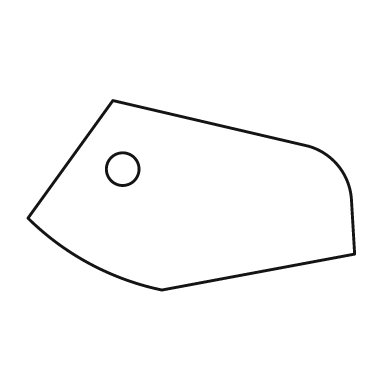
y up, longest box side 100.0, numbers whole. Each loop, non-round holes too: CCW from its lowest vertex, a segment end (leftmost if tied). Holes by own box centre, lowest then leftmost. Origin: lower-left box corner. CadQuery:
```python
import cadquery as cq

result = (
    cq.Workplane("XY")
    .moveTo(41.0, 0.0)
    .lineTo(100.0, 11.0)
    .lineTo(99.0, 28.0)
    .threePointArc((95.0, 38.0), (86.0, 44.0))
    .lineTo(26.0, 58.0)
    .lineTo(0.0, 22.0)
    .threePointArc((19.0, 8.0), (41.0, 0.0))
    .close()
    .moveTo(29.0, 37.0)
    .circle(5.0)
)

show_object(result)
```